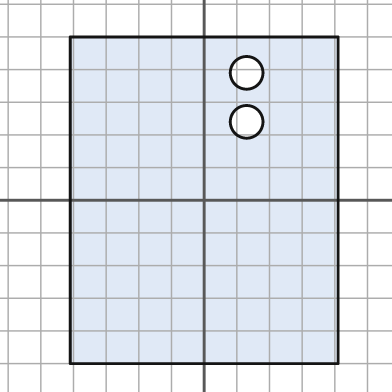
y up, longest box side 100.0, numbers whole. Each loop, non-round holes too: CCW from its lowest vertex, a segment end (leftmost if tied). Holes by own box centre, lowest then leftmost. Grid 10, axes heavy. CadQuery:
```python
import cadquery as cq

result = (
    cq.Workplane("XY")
    .moveTo(-41.0, -50.0)
    .lineTo(41.0, -50.0)
    .lineTo(41.0, 50.0)
    .lineTo(-41.0, 50.0)
    .close()
    .moveTo(13.0, 24.0)
    .circle(5.0)
    .moveTo(13.0, 39.0)
    .circle(5.0)
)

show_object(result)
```